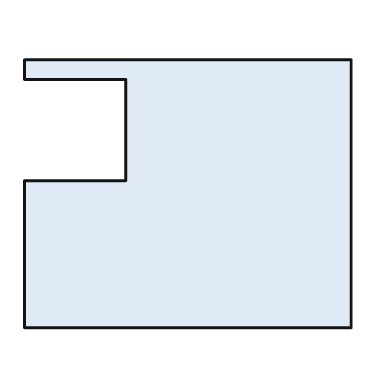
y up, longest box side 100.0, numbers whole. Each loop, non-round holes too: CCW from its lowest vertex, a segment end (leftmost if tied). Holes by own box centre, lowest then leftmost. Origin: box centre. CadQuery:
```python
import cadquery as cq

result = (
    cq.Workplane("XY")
    .moveTo(-50.0, -41.0)
    .lineTo(50.0, -41.0)
    .lineTo(50.0, 41.0)
    .lineTo(-50.0, 41.0)
    .lineTo(-50.0, 35.0)
    .lineTo(-19.0, 35.0)
    .lineTo(-19.0, 4.0)
    .lineTo(-50.0, 4.0)
    .close()
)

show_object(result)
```